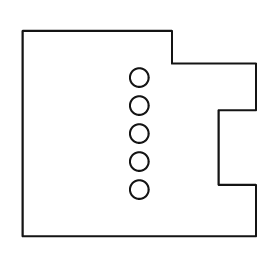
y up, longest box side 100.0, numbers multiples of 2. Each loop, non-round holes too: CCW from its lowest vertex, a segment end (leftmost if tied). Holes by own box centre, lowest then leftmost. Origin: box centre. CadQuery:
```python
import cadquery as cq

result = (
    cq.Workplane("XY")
    .moveTo(-50.0, -44.0)
    .lineTo(50.0, -44.0)
    .lineTo(50.0, -22.0)
    .lineTo(34.0, -22.0)
    .lineTo(34.0, 10.0)
    .lineTo(50.0, 10.0)
    .lineTo(50.0, 30.0)
    .lineTo(14.0, 30.0)
    .lineTo(14.0, 44.0)
    .lineTo(-50.0, 44.0)
    .close()
    .moveTo(0.0, -24.0)
    .circle(4.0)
    .moveTo(0.0, -12.0)
    .circle(4.0)
    .moveTo(0.0, 0.0)
    .circle(4.0)
    .moveTo(0.0, 12.0)
    .circle(4.0)
    .moveTo(0.0, 24.0)
    .circle(4.0)
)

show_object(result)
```